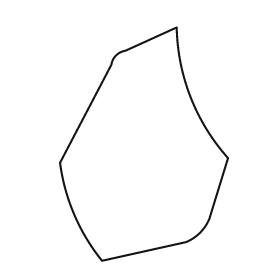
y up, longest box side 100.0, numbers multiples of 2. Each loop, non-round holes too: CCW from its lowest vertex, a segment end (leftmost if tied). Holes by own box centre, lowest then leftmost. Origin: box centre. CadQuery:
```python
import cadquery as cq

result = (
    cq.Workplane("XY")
    .moveTo(-18.0, -50.0)
    .lineTo(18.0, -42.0)
    .threePointArc((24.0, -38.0), (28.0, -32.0))
    .lineTo(36.0, -6.0)
    .threePointArc((20.0, 20.0), (14.0, 50.0))
    .lineTo(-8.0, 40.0)
    .threePointArc((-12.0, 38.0), (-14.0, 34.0))
    .lineTo(-36.0, -8.0)
    .threePointArc((-30.0, -30.0), (-18.0, -50.0))
    .close()
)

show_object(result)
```